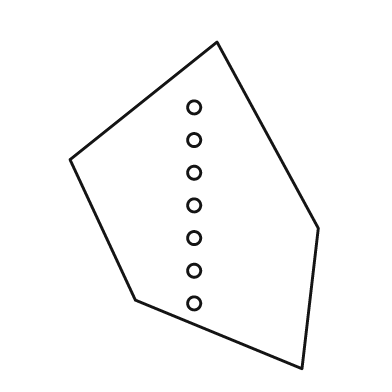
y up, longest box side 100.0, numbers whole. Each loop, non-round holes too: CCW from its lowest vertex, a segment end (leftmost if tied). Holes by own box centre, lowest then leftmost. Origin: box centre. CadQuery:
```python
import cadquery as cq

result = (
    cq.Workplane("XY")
    .moveTo(33.0, -50.0)
    .lineTo(38.0, -7.0)
    .lineTo(7.0, 50.0)
    .lineTo(-38.0, 14.0)
    .lineTo(-18.0, -29.0)
    .close()
    .moveTo(0.0, -30.0)
    .circle(2.0)
    .moveTo(0.0, -20.0)
    .circle(2.0)
    .moveTo(0.0, -10.0)
    .circle(2.0)
    .moveTo(0.0, 0.0)
    .circle(2.0)
    .moveTo(0.0, 10.0)
    .circle(2.0)
    .moveTo(0.0, 20.0)
    .circle(2.0)
    .moveTo(0.0, 30.0)
    .circle(2.0)
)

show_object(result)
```